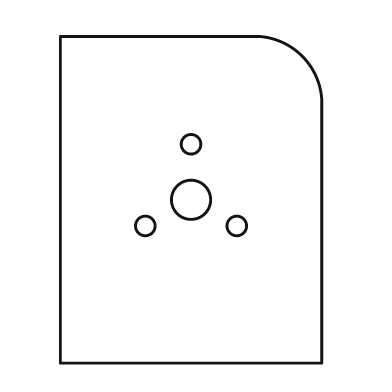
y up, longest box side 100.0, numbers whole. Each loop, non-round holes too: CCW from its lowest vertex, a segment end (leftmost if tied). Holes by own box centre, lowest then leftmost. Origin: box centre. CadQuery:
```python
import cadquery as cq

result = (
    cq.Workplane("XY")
    .moveTo(-40.0, -50.0)
    .lineTo(40.0, -50.0)
    .lineTo(40.0, 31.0)
    .threePointArc((34.0, 44.0), (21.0, 50.0))
    .lineTo(-40.0, 50.0)
    .close()
    .moveTo(-14.0, -8.0)
    .circle(3.0)
    .moveTo(14.0, -8.0)
    .circle(3.0)
    .moveTo(0.0, 0.0)
    .circle(6.0)
    .moveTo(0.0, 17.0)
    .circle(3.0)
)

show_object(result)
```